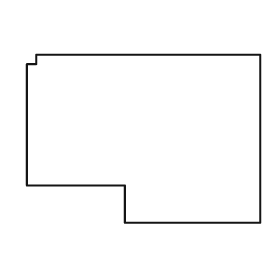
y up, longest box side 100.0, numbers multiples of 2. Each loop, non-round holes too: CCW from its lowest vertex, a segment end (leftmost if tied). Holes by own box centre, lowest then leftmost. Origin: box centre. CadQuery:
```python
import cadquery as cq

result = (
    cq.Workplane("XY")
    .moveTo(-8.0, -36.0)
    .lineTo(50.0, -36.0)
    .lineTo(50.0, 36.0)
    .lineTo(-46.0, 36.0)
    .lineTo(-46.0, 32.0)
    .lineTo(-50.0, 32.0)
    .lineTo(-50.0, -20.0)
    .lineTo(-8.0, -20.0)
    .close()
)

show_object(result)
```